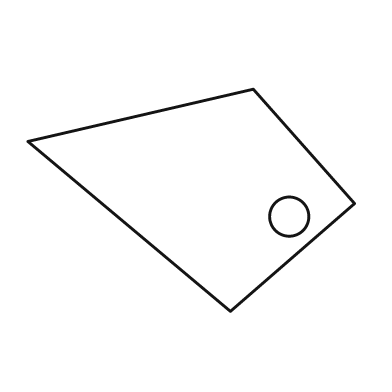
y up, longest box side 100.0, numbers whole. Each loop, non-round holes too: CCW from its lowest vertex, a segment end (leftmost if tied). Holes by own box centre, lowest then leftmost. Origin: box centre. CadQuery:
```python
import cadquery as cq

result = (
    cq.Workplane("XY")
    .moveTo(12.0, -34.0)
    .lineTo(50.0, -1.0)
    .lineTo(19.0, 34.0)
    .lineTo(-50.0, 18.0)
    .close()
    .moveTo(30.0, -5.0)
    .circle(6.0)
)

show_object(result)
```